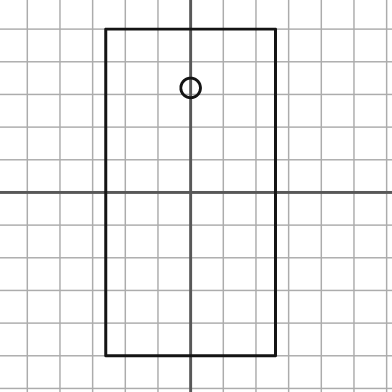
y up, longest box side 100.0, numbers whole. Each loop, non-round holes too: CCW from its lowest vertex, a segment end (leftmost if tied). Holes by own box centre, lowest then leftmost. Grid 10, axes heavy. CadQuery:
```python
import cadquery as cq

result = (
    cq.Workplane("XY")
    .moveTo(-26.0, -50.0)
    .lineTo(26.0, -50.0)
    .lineTo(26.0, 50.0)
    .lineTo(-26.0, 50.0)
    .close()
    .moveTo(0.0, 32.0)
    .circle(3.0)
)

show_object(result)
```